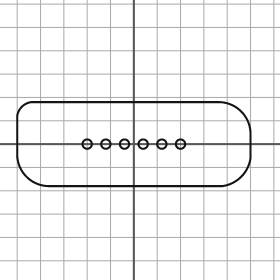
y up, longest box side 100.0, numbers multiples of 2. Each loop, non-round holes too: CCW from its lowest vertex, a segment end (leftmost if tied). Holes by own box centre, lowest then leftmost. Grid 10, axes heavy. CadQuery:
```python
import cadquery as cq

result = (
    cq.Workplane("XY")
    .moveTo(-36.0, -18.0)
    .lineTo(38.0, -18.0)
    .threePointArc((46.0, -14.0), (50.0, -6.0))
    .lineTo(50.0, 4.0)
    .threePointArc((46.0, 14.0), (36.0, 18.0))
    .lineTo(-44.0, 18.0)
    .threePointArc((-48.0, 16.0), (-50.0, 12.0))
    .lineTo(-50.0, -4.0)
    .threePointArc((-46.0, -14.0), (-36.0, -18.0))
    .close()
    .moveTo(-20.0, 0.0)
    .circle(2.0)
    .moveTo(-12.0, 0.0)
    .circle(2.0)
    .moveTo(-4.0, 0.0)
    .circle(2.0)
    .moveTo(4.0, 0.0)
    .circle(2.0)
    .moveTo(12.0, 0.0)
    .circle(2.0)
    .moveTo(20.0, 0.0)
    .circle(2.0)
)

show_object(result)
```